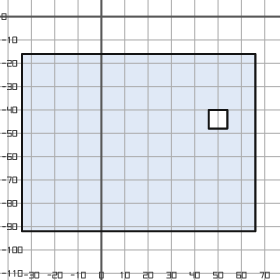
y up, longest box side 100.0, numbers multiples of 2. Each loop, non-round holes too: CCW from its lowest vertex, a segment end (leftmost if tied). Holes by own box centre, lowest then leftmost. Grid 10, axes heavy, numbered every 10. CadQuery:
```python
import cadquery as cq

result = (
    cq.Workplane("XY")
    .moveTo(-34.0, -92.0)
    .lineTo(66.0, -92.0)
    .lineTo(66.0, -16.0)
    .lineTo(-34.0, -16.0)
    .close()
    .moveTo(46.0, -48.0)
    .lineTo(54.0, -48.0)
    .lineTo(54.0, -40.0)
    .lineTo(46.0, -40.0)
    .close()
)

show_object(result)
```